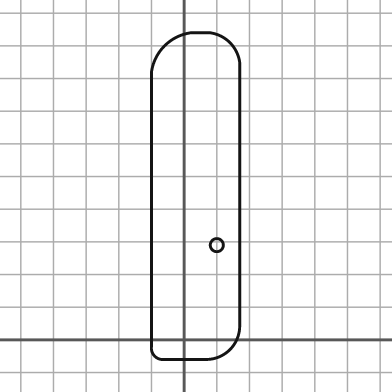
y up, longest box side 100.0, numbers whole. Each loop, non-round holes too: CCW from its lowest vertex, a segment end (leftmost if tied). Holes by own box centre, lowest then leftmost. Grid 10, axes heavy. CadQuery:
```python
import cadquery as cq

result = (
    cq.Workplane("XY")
    .moveTo(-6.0, -6.0)
    .lineTo(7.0, -6.0)
    .threePointArc((14.0, -3.0), (17.0, 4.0))
    .lineTo(17.0, 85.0)
    .threePointArc((14.0, 91.0), (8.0, 94.0))
    .lineTo(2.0, 94.0)
    .threePointArc((-6.0, 90.0), (-10.0, 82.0))
    .lineTo(-10.0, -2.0)
    .threePointArc((-9.0, -5.0), (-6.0, -6.0))
    .close()
    .moveTo(10.0, 29.0)
    .circle(2.0)
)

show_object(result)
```